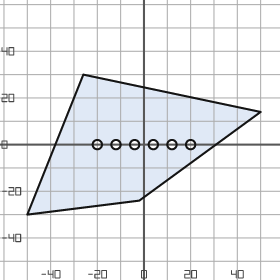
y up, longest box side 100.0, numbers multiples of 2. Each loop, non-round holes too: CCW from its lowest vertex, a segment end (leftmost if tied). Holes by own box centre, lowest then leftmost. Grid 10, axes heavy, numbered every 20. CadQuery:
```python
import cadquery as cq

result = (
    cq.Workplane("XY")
    .moveTo(-50.0, -30.0)
    .lineTo(-2.0, -24.0)
    .lineTo(50.0, 14.0)
    .lineTo(-26.0, 30.0)
    .close()
    .moveTo(-20.0, 0.0)
    .circle(2.0)
    .moveTo(-12.0, 0.0)
    .circle(2.0)
    .moveTo(-4.0, 0.0)
    .circle(2.0)
    .moveTo(4.0, 0.0)
    .circle(2.0)
    .moveTo(12.0, 0.0)
    .circle(2.0)
    .moveTo(20.0, 0.0)
    .circle(2.0)
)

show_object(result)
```